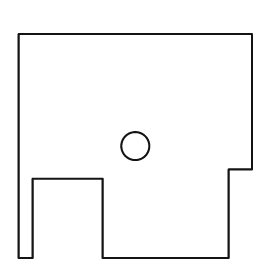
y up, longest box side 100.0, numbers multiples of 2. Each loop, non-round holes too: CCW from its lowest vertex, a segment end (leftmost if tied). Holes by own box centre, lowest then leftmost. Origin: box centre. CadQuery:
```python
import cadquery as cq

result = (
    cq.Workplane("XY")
    .moveTo(-50.0, -48.0)
    .lineTo(-44.0, -48.0)
    .lineTo(-44.0, -14.0)
    .lineTo(-14.0, -14.0)
    .lineTo(-14.0, -48.0)
    .lineTo(40.0, -48.0)
    .lineTo(40.0, -10.0)
    .lineTo(50.0, -10.0)
    .lineTo(50.0, 48.0)
    .lineTo(-50.0, 48.0)
    .close()
    .moveTo(0.0, 0.0)
    .circle(6.0)
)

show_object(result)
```